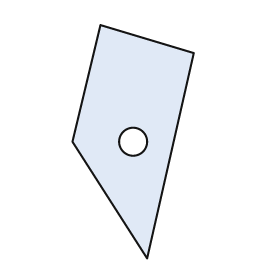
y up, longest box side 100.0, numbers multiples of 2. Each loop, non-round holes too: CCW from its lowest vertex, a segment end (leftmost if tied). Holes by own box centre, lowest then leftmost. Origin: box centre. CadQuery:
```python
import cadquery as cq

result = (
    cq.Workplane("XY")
    .moveTo(6.0, -50.0)
    .lineTo(26.0, 38.0)
    .lineTo(-14.0, 50.0)
    .lineTo(-26.0, 0.0)
    .close()
    .moveTo(0.0, 0.0)
    .circle(6.0)
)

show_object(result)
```